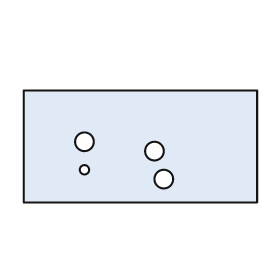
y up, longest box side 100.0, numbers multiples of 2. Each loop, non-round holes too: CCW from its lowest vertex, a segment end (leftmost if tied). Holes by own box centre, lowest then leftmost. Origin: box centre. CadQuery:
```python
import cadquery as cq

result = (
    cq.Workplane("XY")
    .moveTo(-50.0, -24.0)
    .lineTo(50.0, -24.0)
    .lineTo(50.0, 24.0)
    .lineTo(-50.0, 24.0)
    .close()
    .moveTo(10.0, -14.0)
    .circle(4.0)
    .moveTo(-24.0, -10.0)
    .circle(2.0)
    .moveTo(6.0, -2.0)
    .circle(4.0)
    .moveTo(-24.0, 2.0)
    .circle(4.0)
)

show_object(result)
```